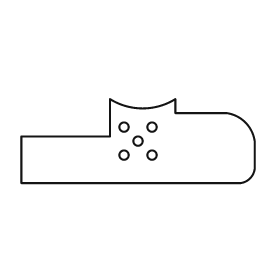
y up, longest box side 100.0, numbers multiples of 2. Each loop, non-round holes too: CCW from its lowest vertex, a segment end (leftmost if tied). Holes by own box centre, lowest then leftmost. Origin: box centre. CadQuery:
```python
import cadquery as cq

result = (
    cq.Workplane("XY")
    .moveTo(-50.0, -18.0)
    .lineTo(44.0, -18.0)
    .threePointArc((48.0, -16.0), (50.0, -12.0))
    .lineTo(50.0, 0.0)
    .threePointArc((46.0, 8.0), (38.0, 12.0))
    .lineTo(16.0, 12.0)
    .lineTo(16.0, 18.0)
    .threePointArc((2.0, 14.0), (-12.0, 18.0))
    .lineTo(-12.0, 2.0)
    .lineTo(-50.0, 2.0)
    .close()
    .moveTo(-6.0, -6.0)
    .circle(2.0)
    .moveTo(6.0, -6.0)
    .circle(2.0)
    .moveTo(0.0, 0.0)
    .circle(2.0)
    .moveTo(-6.0, 6.0)
    .circle(2.0)
    .moveTo(6.0, 6.0)
    .circle(2.0)
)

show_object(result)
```